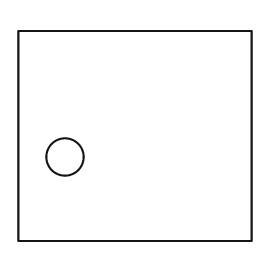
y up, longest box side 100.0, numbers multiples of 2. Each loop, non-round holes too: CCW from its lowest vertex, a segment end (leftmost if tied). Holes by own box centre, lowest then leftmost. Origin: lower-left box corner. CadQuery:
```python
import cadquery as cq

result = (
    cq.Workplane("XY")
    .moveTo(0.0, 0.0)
    .lineTo(100.0, 0.0)
    .lineTo(100.0, 90.0)
    .lineTo(0.0, 90.0)
    .close()
    .moveTo(20.0, 36.0)
    .circle(8.0)
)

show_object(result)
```